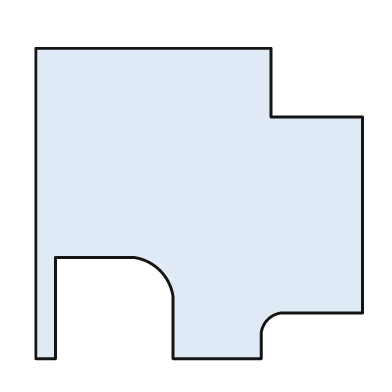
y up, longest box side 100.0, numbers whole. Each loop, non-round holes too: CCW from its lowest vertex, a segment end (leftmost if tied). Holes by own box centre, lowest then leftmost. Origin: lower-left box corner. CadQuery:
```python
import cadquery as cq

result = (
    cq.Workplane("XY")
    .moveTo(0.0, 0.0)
    .lineTo(6.0, 0.0)
    .lineTo(6.0, 31.0)
    .lineTo(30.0, 31.0)
    .threePointArc((38.0, 27.0), (42.0, 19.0))
    .lineTo(42.0, 0.0)
    .lineTo(69.0, 0.0)
    .lineTo(69.0, 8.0)
    .threePointArc((71.0, 12.0), (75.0, 14.0))
    .lineTo(100.0, 14.0)
    .lineTo(100.0, 74.0)
    .lineTo(72.0, 74.0)
    .lineTo(72.0, 95.0)
    .lineTo(0.0, 95.0)
    .close()
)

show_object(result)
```